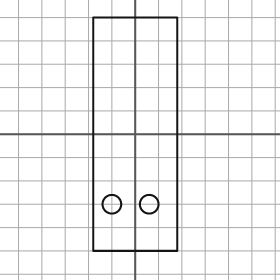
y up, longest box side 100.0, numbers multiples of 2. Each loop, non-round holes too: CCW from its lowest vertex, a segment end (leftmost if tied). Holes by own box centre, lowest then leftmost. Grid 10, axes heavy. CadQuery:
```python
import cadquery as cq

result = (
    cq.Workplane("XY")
    .moveTo(-18.0, -50.0)
    .lineTo(18.0, -50.0)
    .lineTo(18.0, 50.0)
    .lineTo(-18.0, 50.0)
    .close()
    .moveTo(-10.0, -30.0)
    .circle(4.0)
    .moveTo(6.0, -30.0)
    .circle(4.0)
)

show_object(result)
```